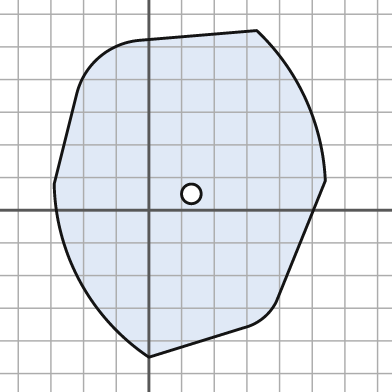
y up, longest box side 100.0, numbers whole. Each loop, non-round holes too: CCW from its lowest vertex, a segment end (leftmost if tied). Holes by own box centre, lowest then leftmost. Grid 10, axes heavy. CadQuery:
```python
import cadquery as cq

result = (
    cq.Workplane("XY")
    .moveTo(0.0, -45.0)
    .lineTo(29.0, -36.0)
    .threePointArc((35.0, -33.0), (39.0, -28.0))
    .lineTo(54.0, 9.0)
    .threePointArc((48.0, 34.0), (33.0, 55.0))
    .lineTo(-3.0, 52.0)
    .threePointArc((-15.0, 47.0), (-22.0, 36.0))
    .lineTo(-29.0, 8.0)
    .threePointArc((-21.0, -22.0), (0.0, -45.0))
    .close()
    .moveTo(13.0, 5.0)
    .circle(3.0)
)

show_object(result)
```